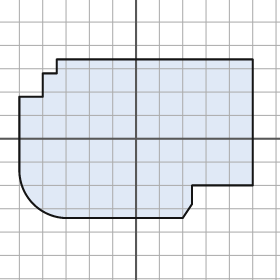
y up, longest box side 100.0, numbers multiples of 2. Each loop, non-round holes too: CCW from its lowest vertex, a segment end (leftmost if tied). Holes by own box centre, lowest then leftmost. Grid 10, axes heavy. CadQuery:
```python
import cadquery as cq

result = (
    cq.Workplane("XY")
    .moveTo(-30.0, -34.0)
    .lineTo(20.0, -34.0)
    .lineTo(24.0, -28.0)
    .lineTo(24.0, -20.0)
    .lineTo(50.0, -20.0)
    .lineTo(50.0, 34.0)
    .lineTo(-34.0, 34.0)
    .lineTo(-34.0, 28.0)
    .lineTo(-40.0, 28.0)
    .lineTo(-40.0, 18.0)
    .lineTo(-50.0, 18.0)
    .lineTo(-50.0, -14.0)
    .threePointArc((-44.0, -28.0), (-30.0, -34.0))
    .close()
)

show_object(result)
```